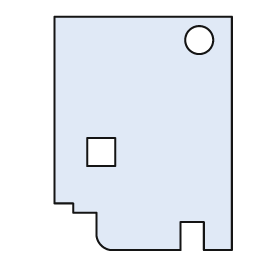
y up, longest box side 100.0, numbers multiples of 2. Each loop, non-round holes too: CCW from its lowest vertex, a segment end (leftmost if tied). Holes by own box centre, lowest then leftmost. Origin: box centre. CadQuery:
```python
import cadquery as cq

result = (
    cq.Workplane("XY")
    .moveTo(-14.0, -50.0)
    .lineTo(16.0, -50.0)
    .lineTo(16.0, -38.0)
    .lineTo(26.0, -38.0)
    .lineTo(26.0, -50.0)
    .lineTo(38.0, -50.0)
    .lineTo(38.0, 50.0)
    .lineTo(-38.0, 50.0)
    .lineTo(-38.0, -30.0)
    .lineTo(-30.0, -30.0)
    .lineTo(-30.0, -34.0)
    .lineTo(-20.0, -34.0)
    .lineTo(-20.0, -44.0)
    .threePointArc((-18.0, -48.0), (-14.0, -50.0))
    .close()
    .moveTo(-24.0, -14.0)
    .lineTo(-12.0, -14.0)
    .lineTo(-12.0, -2.0)
    .lineTo(-24.0, -2.0)
    .close()
    .moveTo(24.0, 40.0)
    .circle(6.0)
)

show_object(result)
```